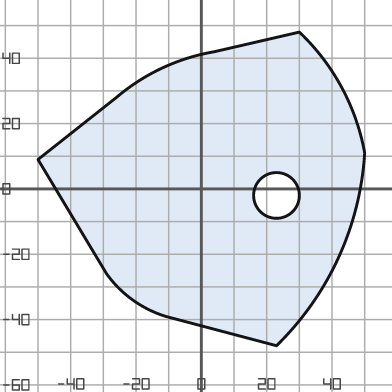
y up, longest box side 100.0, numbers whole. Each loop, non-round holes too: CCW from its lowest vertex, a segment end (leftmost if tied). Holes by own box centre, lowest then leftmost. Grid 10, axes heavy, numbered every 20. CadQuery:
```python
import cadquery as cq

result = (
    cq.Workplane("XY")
    .moveTo(23.0, -48.0)
    .threePointArc((42.0, -21.0), (50.0, 11.0))
    .threePointArc((43.0, 31.0), (30.0, 48.0))
    .lineTo(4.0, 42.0)
    .threePointArc((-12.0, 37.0), (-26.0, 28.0))
    .lineTo(-50.0, 9.0)
    .lineTo(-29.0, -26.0)
    .threePointArc((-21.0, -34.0), (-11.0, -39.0))
    .close()
    .moveTo(23.0, -2.0)
    .circle(7.0)
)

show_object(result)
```